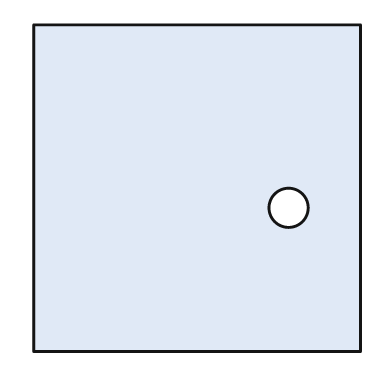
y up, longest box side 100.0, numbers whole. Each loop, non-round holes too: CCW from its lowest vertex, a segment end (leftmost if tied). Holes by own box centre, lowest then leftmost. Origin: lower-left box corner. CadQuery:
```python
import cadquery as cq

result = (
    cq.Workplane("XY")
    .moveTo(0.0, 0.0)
    .lineTo(100.0, 0.0)
    .lineTo(100.0, 100.0)
    .lineTo(0.0, 100.0)
    .close()
    .moveTo(78.0, 44.0)
    .circle(6.0)
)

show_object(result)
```